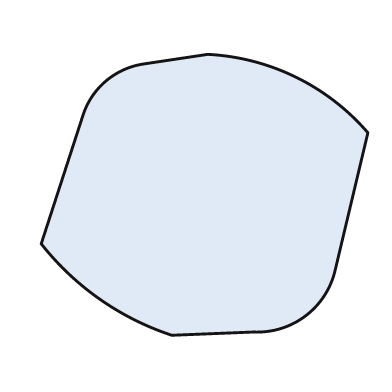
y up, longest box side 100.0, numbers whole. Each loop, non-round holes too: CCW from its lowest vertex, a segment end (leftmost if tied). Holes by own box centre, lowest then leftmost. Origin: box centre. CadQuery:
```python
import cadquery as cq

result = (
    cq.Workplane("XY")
    .moveTo(-10.0, -43.0)
    .lineTo(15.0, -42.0)
    .threePointArc((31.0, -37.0), (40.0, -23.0))
    .lineTo(50.0, 19.0)
    .threePointArc((28.0, 36.0), (1.0, 43.0))
    .lineTo(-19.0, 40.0)
    .threePointArc((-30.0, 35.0), (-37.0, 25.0))
    .lineTo(-50.0, -15.0)
    .threePointArc((-32.0, -32.0), (-10.0, -43.0))
    .close()
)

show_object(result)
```